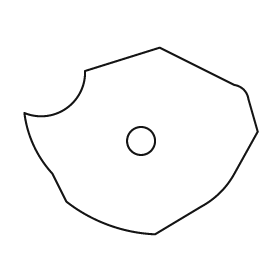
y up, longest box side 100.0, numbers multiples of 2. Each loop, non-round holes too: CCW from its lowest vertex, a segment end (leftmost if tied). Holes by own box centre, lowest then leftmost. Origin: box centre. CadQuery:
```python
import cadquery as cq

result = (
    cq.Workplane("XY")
    .moveTo(6.0, -40.0)
    .lineTo(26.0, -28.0)
    .threePointArc((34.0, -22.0), (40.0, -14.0))
    .lineTo(50.0, 4.0)
    .lineTo(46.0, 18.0)
    .threePointArc((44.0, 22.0), (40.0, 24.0))
    .lineTo(8.0, 40.0)
    .lineTo(-24.0, 30.0)
    .threePointArc((-32.0, 14.0), (-50.0, 12.0))
    .threePointArc((-46.0, -2.0), (-38.0, -14.0))
    .lineTo(-32.0, -26.0)
    .threePointArc((-14.0, -36.0), (6.0, -40.0))
    .close()
    .moveTo(0.0, 0.0)
    .circle(6.0)
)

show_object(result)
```